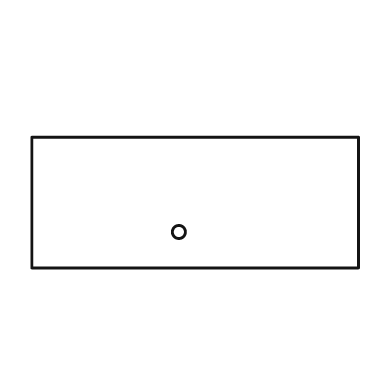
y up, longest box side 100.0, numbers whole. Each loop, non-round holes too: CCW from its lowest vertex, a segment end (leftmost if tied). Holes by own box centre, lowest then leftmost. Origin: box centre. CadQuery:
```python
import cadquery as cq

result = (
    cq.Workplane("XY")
    .moveTo(-50.0, -20.0)
    .lineTo(50.0, -20.0)
    .lineTo(50.0, 20.0)
    .lineTo(-50.0, 20.0)
    .close()
    .moveTo(-5.0, -9.0)
    .circle(2.0)
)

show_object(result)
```